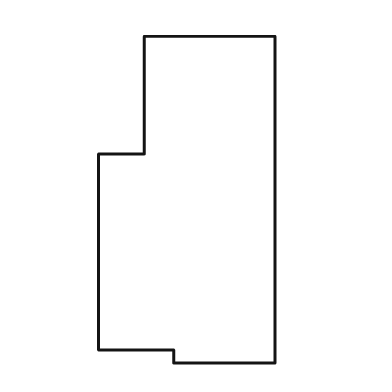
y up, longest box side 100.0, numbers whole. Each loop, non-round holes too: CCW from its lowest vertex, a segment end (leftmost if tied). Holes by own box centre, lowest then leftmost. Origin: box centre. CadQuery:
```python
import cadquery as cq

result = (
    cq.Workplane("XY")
    .moveTo(-4.0, -50.0)
    .lineTo(27.0, -50.0)
    .lineTo(27.0, 50.0)
    .lineTo(-13.0, 50.0)
    .lineTo(-13.0, 14.0)
    .lineTo(-27.0, 14.0)
    .lineTo(-27.0, -46.0)
    .lineTo(-4.0, -46.0)
    .close()
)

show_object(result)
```